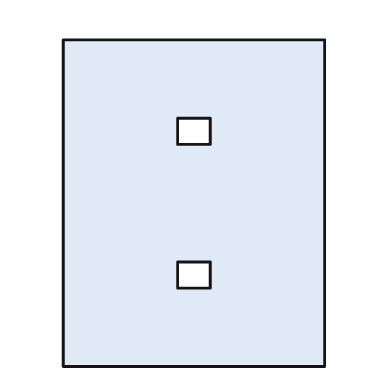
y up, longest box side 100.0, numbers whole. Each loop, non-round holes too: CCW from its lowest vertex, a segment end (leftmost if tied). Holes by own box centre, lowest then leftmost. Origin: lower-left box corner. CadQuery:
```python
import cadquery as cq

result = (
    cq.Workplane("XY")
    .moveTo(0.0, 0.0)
    .lineTo(80.0, 0.0)
    .lineTo(80.0, 100.0)
    .lineTo(0.0, 100.0)
    .close()
    .moveTo(35.0, 24.0)
    .lineTo(45.0, 24.0)
    .lineTo(45.0, 32.0)
    .lineTo(35.0, 32.0)
    .close()
    .moveTo(35.0, 68.0)
    .lineTo(45.0, 68.0)
    .lineTo(45.0, 76.0)
    .lineTo(35.0, 76.0)
    .close()
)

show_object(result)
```